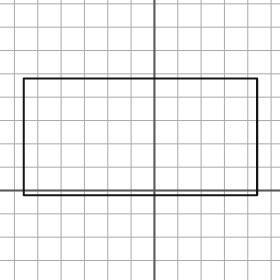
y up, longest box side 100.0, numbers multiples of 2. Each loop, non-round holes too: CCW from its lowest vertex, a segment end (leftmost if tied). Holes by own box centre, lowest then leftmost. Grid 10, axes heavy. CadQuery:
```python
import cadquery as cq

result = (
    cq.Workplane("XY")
    .moveTo(-56.0, -2.0)
    .lineTo(44.0, -2.0)
    .lineTo(44.0, 48.0)
    .lineTo(-56.0, 48.0)
    .close()
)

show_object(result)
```